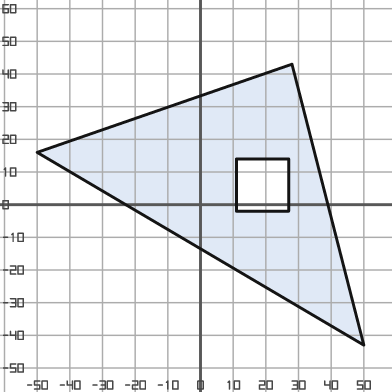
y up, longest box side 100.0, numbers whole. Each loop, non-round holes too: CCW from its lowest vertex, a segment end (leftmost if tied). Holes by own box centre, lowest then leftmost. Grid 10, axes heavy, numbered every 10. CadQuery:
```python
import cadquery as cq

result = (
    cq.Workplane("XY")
    .moveTo(50.0, -43.0)
    .lineTo(28.0, 43.0)
    .lineTo(-50.0, 16.0)
    .close()
    .moveTo(11.0, -2.0)
    .lineTo(27.0, -2.0)
    .lineTo(27.0, 14.0)
    .lineTo(11.0, 14.0)
    .close()
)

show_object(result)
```